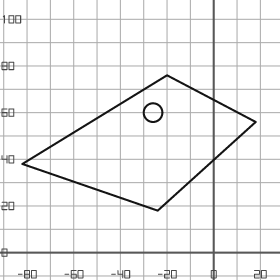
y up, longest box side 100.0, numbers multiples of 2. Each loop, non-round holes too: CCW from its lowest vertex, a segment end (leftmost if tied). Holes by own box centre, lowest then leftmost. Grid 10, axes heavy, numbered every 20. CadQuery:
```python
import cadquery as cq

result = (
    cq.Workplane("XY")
    .moveTo(-24.0, 18.0)
    .lineTo(18.0, 56.0)
    .lineTo(-20.0, 76.0)
    .lineTo(-82.0, 38.0)
    .close()
    .moveTo(-26.0, 60.0)
    .circle(4.0)
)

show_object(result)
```